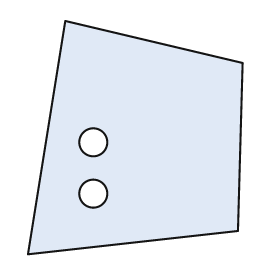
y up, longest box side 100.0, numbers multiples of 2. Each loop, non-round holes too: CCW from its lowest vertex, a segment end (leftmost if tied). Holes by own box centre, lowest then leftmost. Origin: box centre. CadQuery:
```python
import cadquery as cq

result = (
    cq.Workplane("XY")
    .moveTo(-46.0, -50.0)
    .lineTo(44.0, -40.0)
    .lineTo(46.0, 32.0)
    .lineTo(-30.0, 50.0)
    .close()
    .moveTo(-18.0, -24.0)
    .circle(6.0)
    .moveTo(-18.0, -2.0)
    .circle(6.0)
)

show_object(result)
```